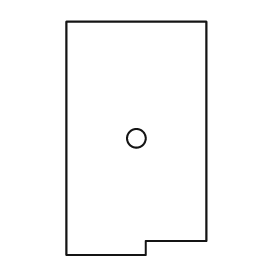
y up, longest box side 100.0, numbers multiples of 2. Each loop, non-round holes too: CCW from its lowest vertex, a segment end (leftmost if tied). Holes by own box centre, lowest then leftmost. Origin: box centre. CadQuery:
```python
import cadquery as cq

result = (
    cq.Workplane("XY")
    .moveTo(-30.0, -50.0)
    .lineTo(4.0, -50.0)
    .lineTo(4.0, -44.0)
    .lineTo(30.0, -44.0)
    .lineTo(30.0, 50.0)
    .lineTo(-30.0, 50.0)
    .close()
    .moveTo(0.0, 0.0)
    .circle(4.0)
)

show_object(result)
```